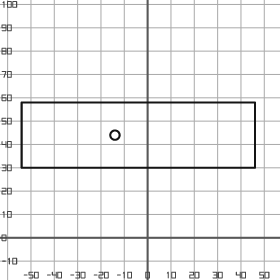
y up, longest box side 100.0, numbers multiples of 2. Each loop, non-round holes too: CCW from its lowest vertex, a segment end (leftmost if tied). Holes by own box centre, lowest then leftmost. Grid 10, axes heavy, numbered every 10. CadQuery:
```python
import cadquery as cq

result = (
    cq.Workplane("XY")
    .moveTo(-54.0, 30.0)
    .lineTo(46.0, 30.0)
    .lineTo(46.0, 58.0)
    .lineTo(-54.0, 58.0)
    .close()
    .moveTo(-14.0, 44.0)
    .circle(2.0)
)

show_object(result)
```